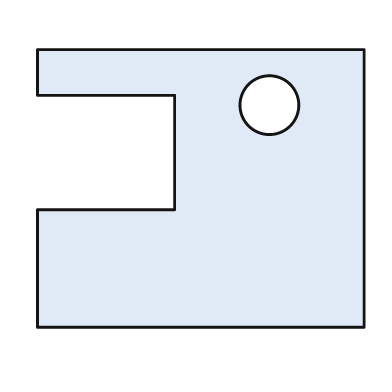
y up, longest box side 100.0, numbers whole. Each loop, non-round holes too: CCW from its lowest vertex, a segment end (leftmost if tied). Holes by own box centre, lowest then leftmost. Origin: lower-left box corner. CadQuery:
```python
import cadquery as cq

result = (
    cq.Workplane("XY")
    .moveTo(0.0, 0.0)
    .lineTo(100.0, 0.0)
    .lineTo(100.0, 85.0)
    .lineTo(0.0, 85.0)
    .lineTo(0.0, 71.0)
    .lineTo(42.0, 71.0)
    .lineTo(42.0, 36.0)
    .lineTo(0.0, 36.0)
    .close()
    .moveTo(71.0, 68.0)
    .circle(9.0)
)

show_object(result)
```